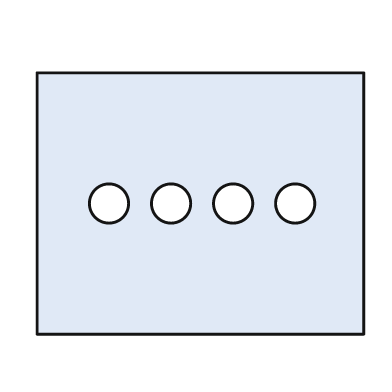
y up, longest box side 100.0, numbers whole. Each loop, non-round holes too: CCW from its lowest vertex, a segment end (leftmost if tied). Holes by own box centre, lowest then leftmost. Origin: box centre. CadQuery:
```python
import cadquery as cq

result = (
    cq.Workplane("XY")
    .moveTo(-50.0, -40.0)
    .lineTo(50.0, -40.0)
    .lineTo(50.0, 40.0)
    .lineTo(-50.0, 40.0)
    .close()
    .moveTo(-28.0, 0.0)
    .circle(6.0)
    .moveTo(-9.0, 0.0)
    .circle(6.0)
    .moveTo(10.0, 0.0)
    .circle(6.0)
    .moveTo(29.0, 0.0)
    .circle(6.0)
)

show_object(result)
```